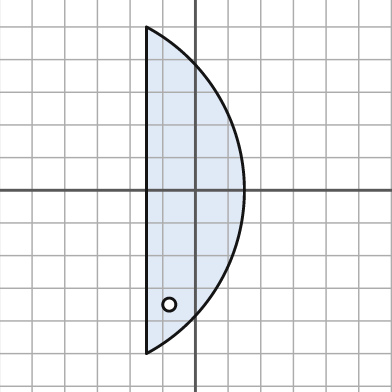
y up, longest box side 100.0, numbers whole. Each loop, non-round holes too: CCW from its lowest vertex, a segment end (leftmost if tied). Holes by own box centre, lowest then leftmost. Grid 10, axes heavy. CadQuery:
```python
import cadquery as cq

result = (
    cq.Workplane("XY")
    .moveTo(-15.0, -50.0)
    .threePointArc((15.0, 0.0), (-15.0, 50.0))
    .close()
    .moveTo(-8.0, -35.0)
    .circle(2.0)
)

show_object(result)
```